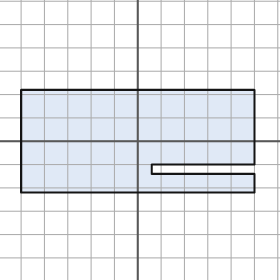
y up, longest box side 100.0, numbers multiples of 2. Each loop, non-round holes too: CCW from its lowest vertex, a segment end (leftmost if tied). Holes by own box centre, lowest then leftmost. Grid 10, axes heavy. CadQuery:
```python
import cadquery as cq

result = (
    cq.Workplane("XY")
    .moveTo(-50.0, -22.0)
    .lineTo(50.0, -22.0)
    .lineTo(50.0, -14.0)
    .lineTo(6.0, -14.0)
    .lineTo(6.0, -10.0)
    .lineTo(50.0, -10.0)
    .lineTo(50.0, 22.0)
    .lineTo(-50.0, 22.0)
    .close()
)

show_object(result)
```